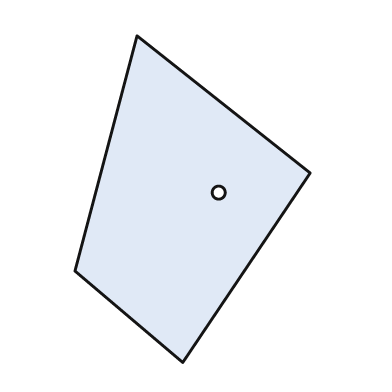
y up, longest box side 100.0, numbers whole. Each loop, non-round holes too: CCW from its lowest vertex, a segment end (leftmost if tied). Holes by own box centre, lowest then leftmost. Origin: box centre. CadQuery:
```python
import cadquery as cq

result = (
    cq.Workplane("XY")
    .moveTo(-3.0, -50.0)
    .lineTo(36.0, 8.0)
    .lineTo(-17.0, 50.0)
    .lineTo(-36.0, -22.0)
    .close()
    .moveTo(8.0, 2.0)
    .circle(2.0)
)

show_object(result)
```